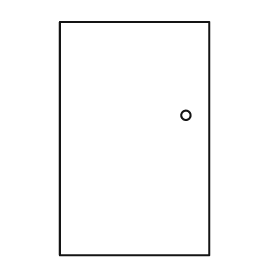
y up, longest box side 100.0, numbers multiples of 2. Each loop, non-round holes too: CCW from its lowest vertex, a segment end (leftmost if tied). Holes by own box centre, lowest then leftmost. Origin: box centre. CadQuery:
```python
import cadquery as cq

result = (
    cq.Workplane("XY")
    .moveTo(-32.0, -50.0)
    .lineTo(32.0, -50.0)
    .lineTo(32.0, 50.0)
    .lineTo(-32.0, 50.0)
    .close()
    .moveTo(22.0, 10.0)
    .circle(2.0)
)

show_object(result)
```